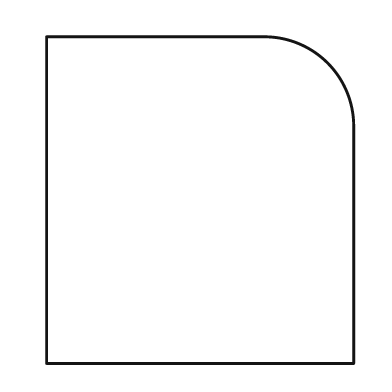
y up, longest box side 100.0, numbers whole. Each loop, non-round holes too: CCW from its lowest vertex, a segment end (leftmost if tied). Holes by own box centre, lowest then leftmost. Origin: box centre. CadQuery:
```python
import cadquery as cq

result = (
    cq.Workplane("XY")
    .moveTo(-47.0, -50.0)
    .lineTo(47.0, -50.0)
    .lineTo(47.0, 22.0)
    .threePointArc((39.0, 42.0), (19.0, 50.0))
    .lineTo(-47.0, 50.0)
    .close()
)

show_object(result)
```